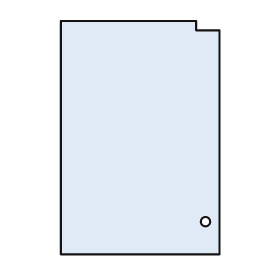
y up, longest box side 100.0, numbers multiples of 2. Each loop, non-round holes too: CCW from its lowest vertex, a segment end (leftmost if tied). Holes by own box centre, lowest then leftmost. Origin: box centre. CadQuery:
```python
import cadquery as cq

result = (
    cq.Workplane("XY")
    .moveTo(-34.0, -50.0)
    .lineTo(34.0, -50.0)
    .lineTo(34.0, 46.0)
    .lineTo(24.0, 46.0)
    .lineTo(24.0, 50.0)
    .lineTo(-34.0, 50.0)
    .close()
    .moveTo(28.0, -36.0)
    .circle(2.0)
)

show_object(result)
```